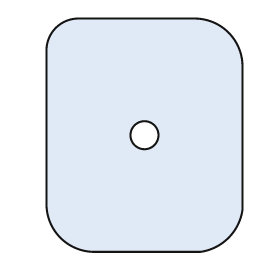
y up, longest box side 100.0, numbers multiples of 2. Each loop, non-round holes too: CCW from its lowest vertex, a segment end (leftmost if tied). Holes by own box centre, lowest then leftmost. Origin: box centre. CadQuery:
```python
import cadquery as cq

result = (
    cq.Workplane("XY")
    .moveTo(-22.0, -50.0)
    .lineTo(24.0, -50.0)
    .threePointArc((36.0, -44.0), (42.0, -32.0))
    .lineTo(42.0, 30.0)
    .threePointArc((36.0, 44.0), (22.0, 50.0))
    .lineTo(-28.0, 50.0)
    .threePointArc((-38.0, 46.0), (-42.0, 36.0))
    .lineTo(-42.0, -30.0)
    .threePointArc((-36.0, -44.0), (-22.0, -50.0))
    .close()
    .moveTo(0.0, 0.0)
    .circle(6.0)
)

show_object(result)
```